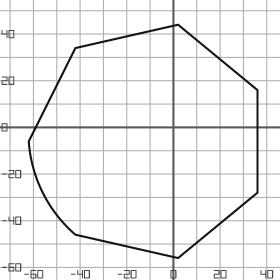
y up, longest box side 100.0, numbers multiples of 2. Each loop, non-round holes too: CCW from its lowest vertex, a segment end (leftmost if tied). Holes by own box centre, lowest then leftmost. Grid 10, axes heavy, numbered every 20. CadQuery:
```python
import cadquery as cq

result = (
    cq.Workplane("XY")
    .moveTo(2.0, -56.0)
    .lineTo(36.0, -28.0)
    .lineTo(36.0, 16.0)
    .lineTo(2.0, 44.0)
    .lineTo(-42.0, 34.0)
    .lineTo(-62.0, -6.0)
    .threePointArc((-56.0, -28.0), (-42.0, -46.0))
    .close()
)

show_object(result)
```